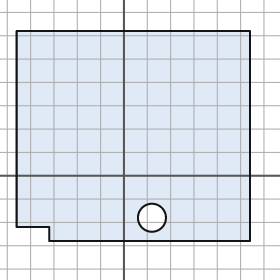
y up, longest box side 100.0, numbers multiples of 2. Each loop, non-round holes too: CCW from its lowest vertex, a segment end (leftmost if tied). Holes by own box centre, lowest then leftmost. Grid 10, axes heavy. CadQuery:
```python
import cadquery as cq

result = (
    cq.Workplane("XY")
    .moveTo(-32.0, -28.0)
    .lineTo(54.0, -28.0)
    .lineTo(54.0, 62.0)
    .lineTo(-46.0, 62.0)
    .lineTo(-46.0, -22.0)
    .lineTo(-32.0, -22.0)
    .close()
    .moveTo(12.0, -18.0)
    .circle(6.0)
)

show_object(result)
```